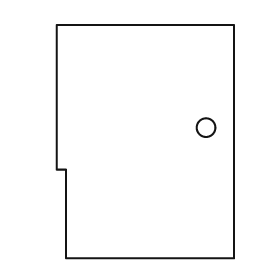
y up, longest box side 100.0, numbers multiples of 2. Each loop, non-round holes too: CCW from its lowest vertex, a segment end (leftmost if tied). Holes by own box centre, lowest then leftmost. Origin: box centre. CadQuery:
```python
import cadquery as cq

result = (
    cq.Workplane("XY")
    .moveTo(-34.0, -50.0)
    .lineTo(38.0, -50.0)
    .lineTo(38.0, 50.0)
    .lineTo(-38.0, 50.0)
    .lineTo(-38.0, -12.0)
    .lineTo(-34.0, -12.0)
    .close()
    .moveTo(26.0, 6.0)
    .circle(4.0)
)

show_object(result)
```